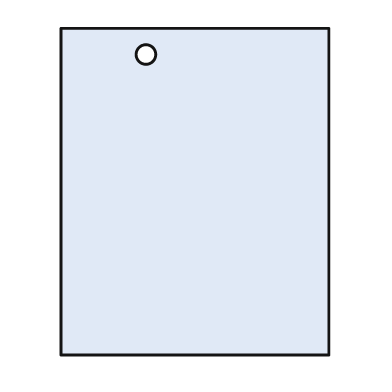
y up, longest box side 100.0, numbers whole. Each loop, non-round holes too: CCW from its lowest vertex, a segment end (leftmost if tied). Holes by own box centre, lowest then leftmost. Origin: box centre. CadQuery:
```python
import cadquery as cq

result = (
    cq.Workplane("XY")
    .moveTo(-41.0, -50.0)
    .lineTo(41.0, -50.0)
    .lineTo(41.0, 50.0)
    .lineTo(-41.0, 50.0)
    .close()
    .moveTo(-15.0, 42.0)
    .circle(3.0)
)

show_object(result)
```